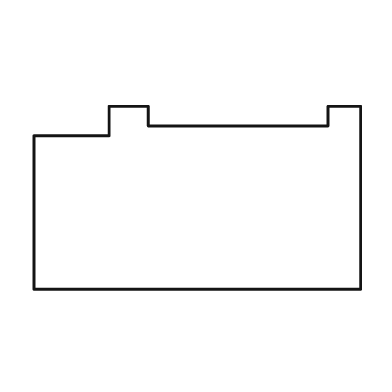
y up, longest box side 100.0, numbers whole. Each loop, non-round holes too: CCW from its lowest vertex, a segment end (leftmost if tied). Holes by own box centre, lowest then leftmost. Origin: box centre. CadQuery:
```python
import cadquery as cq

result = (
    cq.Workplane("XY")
    .moveTo(-50.0, -28.0)
    .lineTo(50.0, -28.0)
    .lineTo(50.0, 28.0)
    .lineTo(40.0, 28.0)
    .lineTo(40.0, 22.0)
    .lineTo(-15.0, 22.0)
    .lineTo(-15.0, 28.0)
    .lineTo(-27.0, 28.0)
    .lineTo(-27.0, 19.0)
    .lineTo(-50.0, 19.0)
    .close()
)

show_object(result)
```